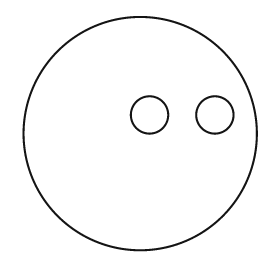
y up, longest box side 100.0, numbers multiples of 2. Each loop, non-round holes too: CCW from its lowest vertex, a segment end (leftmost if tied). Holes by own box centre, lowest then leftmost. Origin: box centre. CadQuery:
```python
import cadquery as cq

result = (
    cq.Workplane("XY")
    .moveTo(0.0, 0.0)
    .circle(50.0)
    .moveTo(4.0, 8.0)
    .circle(8.0)
    .moveTo(32.0, 8.0)
    .circle(8.0)
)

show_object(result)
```